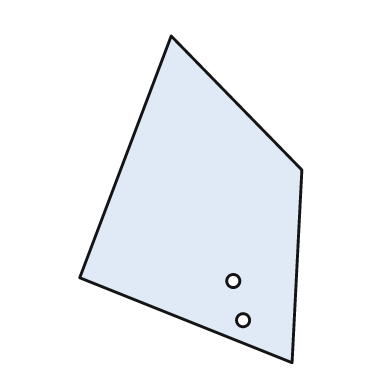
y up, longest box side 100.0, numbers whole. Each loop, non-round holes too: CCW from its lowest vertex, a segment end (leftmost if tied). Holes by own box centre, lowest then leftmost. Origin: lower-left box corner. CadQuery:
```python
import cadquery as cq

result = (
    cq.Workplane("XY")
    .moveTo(65.0, 0.0)
    .lineTo(68.0, 59.0)
    .lineTo(28.0, 100.0)
    .lineTo(0.0, 26.0)
    .close()
    .moveTo(50.0, 13.0)
    .circle(2.0)
    .moveTo(47.0, 25.0)
    .circle(2.0)
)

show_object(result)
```